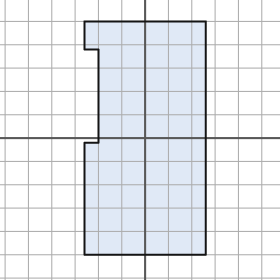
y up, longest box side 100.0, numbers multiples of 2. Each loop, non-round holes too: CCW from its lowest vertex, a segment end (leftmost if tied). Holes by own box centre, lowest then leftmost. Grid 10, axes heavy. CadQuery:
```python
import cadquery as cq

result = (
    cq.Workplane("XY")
    .moveTo(-26.0, -50.0)
    .lineTo(26.0, -50.0)
    .lineTo(26.0, 50.0)
    .lineTo(-26.0, 50.0)
    .lineTo(-26.0, 38.0)
    .lineTo(-20.0, 38.0)
    .lineTo(-20.0, -2.0)
    .lineTo(-26.0, -2.0)
    .close()
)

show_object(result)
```